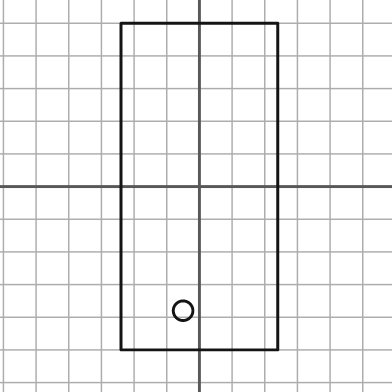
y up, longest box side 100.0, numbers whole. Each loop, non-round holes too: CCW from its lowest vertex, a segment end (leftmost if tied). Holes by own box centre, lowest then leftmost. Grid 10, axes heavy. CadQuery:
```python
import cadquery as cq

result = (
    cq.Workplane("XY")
    .moveTo(-24.0, -50.0)
    .lineTo(24.0, -50.0)
    .lineTo(24.0, 50.0)
    .lineTo(-24.0, 50.0)
    .close()
    .moveTo(-5.0, -38.0)
    .circle(3.0)
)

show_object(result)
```